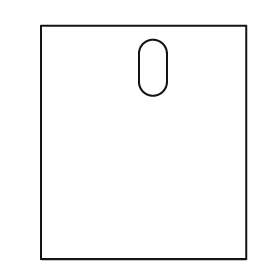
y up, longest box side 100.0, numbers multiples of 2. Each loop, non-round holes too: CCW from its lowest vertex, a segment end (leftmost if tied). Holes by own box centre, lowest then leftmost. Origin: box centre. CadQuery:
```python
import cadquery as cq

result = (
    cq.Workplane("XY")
    .moveTo(-44.0, -50.0)
    .lineTo(44.0, -50.0)
    .lineTo(44.0, 50.0)
    .lineTo(-44.0, 50.0)
    .close()
    .moveTo(-2.0, 26.0)
    .threePointArc((4.0, 20.0), (10.0, 26.0))
    .lineTo(10.0, 38.0)
    .threePointArc((4.0, 44.0), (-2.0, 38.0))
    .close()
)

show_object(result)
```